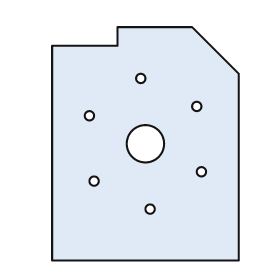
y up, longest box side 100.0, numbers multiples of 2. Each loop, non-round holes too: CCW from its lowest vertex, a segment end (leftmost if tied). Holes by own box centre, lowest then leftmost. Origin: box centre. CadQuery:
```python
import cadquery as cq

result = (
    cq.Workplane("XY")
    .moveTo(-40.0, -50.0)
    .lineTo(40.0, -50.0)
    .lineTo(40.0, 30.0)
    .lineTo(20.0, 50.0)
    .lineTo(-12.0, 50.0)
    .lineTo(-12.0, 42.0)
    .lineTo(-40.0, 42.0)
    .close()
    .moveTo(2.0, -28.0)
    .circle(2.0)
    .moveTo(-22.0, -16.0)
    .circle(2.0)
    .moveTo(24.0, -12.0)
    .circle(2.0)
    .moveTo(0.0, 0.0)
    .circle(8.0)
    .moveTo(-24.0, 12.0)
    .circle(2.0)
    .moveTo(22.0, 16.0)
    .circle(2.0)
    .moveTo(-2.0, 28.0)
    .circle(2.0)
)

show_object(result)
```